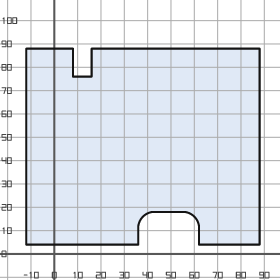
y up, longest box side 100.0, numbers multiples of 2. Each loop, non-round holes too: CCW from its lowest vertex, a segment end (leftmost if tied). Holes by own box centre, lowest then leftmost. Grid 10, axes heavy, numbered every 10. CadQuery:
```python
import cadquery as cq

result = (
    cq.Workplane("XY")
    .moveTo(-12.0, 4.0)
    .lineTo(36.0, 4.0)
    .lineTo(36.0, 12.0)
    .threePointArc((38.0, 16.0), (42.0, 18.0))
    .lineTo(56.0, 18.0)
    .threePointArc((60.0, 16.0), (62.0, 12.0))
    .lineTo(62.0, 4.0)
    .lineTo(88.0, 4.0)
    .lineTo(88.0, 88.0)
    .lineTo(16.0, 88.0)
    .lineTo(16.0, 76.0)
    .lineTo(8.0, 76.0)
    .lineTo(8.0, 88.0)
    .lineTo(-12.0, 88.0)
    .close()
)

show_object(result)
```